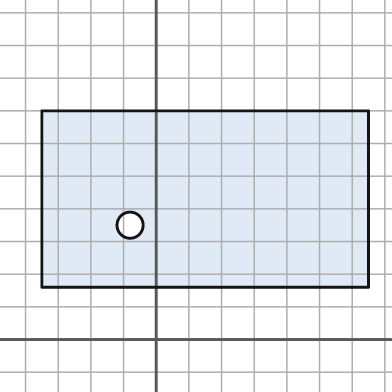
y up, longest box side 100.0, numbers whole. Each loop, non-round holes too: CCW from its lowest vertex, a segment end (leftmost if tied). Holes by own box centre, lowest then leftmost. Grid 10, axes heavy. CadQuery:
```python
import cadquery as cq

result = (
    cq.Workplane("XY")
    .moveTo(-35.0, 16.0)
    .lineTo(65.0, 16.0)
    .lineTo(65.0, 70.0)
    .lineTo(-35.0, 70.0)
    .close()
    .moveTo(-8.0, 35.0)
    .circle(4.0)
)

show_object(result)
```